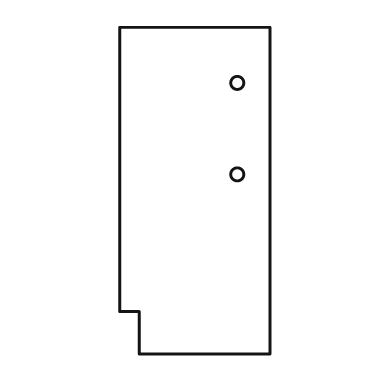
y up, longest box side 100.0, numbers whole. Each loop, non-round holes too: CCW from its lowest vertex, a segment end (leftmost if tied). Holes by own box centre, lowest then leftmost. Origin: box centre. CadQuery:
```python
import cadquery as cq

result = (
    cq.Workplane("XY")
    .moveTo(-17.0, -50.0)
    .lineTo(23.0, -50.0)
    .lineTo(23.0, 50.0)
    .lineTo(-23.0, 50.0)
    .lineTo(-23.0, -37.0)
    .lineTo(-17.0, -37.0)
    .close()
    .moveTo(13.0, 5.0)
    .circle(2.0)
    .moveTo(13.0, 33.0)
    .circle(2.0)
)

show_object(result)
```